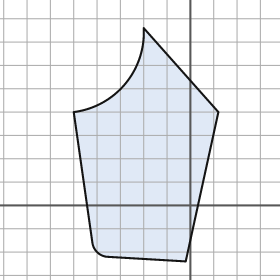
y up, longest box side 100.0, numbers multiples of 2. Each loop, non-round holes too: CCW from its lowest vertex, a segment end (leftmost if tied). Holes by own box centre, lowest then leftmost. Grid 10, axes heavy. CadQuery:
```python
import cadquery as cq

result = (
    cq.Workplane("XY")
    .moveTo(-2.0, -24.0)
    .lineTo(12.0, 40.0)
    .lineTo(-20.0, 76.0)
    .threePointArc((-28.0, 52.0), (-50.0, 40.0))
    .lineTo(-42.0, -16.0)
    .threePointArc((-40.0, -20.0), (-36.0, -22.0))
    .close()
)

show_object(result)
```